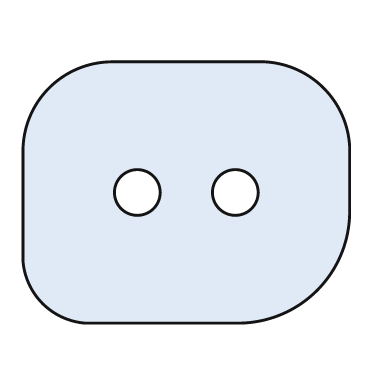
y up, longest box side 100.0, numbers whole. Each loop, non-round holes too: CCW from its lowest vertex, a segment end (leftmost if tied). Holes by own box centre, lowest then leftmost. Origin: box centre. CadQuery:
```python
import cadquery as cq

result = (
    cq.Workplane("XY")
    .moveTo(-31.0, -40.0)
    .lineTo(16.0, -40.0)
    .threePointArc((40.0, -30.0), (50.0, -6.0))
    .lineTo(50.0, 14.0)
    .threePointArc((42.0, 32.0), (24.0, 40.0))
    .lineTo(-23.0, 40.0)
    .threePointArc((-42.0, 32.0), (-50.0, 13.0))
    .lineTo(-50.0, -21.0)
    .threePointArc((-44.0, -34.0), (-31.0, -40.0))
    .close()
    .moveTo(-15.0, 0.0)
    .circle(7.0)
    .moveTo(15.0, 0.0)
    .circle(7.0)
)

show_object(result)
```